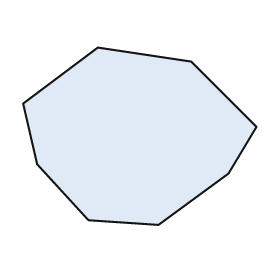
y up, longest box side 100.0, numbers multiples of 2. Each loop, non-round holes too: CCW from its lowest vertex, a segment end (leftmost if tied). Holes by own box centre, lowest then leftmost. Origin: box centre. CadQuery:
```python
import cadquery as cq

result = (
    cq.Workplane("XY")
    .moveTo(8.0, -38.0)
    .lineTo(38.0, -16.0)
    .lineTo(50.0, 4.0)
    .lineTo(22.0, 32.0)
    .lineTo(-18.0, 38.0)
    .lineTo(-50.0, 14.0)
    .lineTo(-44.0, -12.0)
    .lineTo(-22.0, -36.0)
    .close()
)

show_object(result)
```